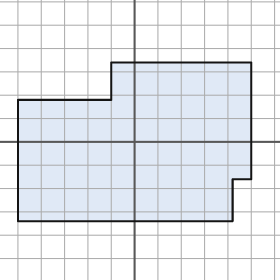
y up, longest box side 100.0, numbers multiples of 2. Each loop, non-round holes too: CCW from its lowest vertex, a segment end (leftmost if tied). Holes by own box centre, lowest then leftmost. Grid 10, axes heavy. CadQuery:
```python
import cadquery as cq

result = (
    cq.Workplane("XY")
    .moveTo(-50.0, -34.0)
    .lineTo(42.0, -34.0)
    .lineTo(42.0, -16.0)
    .lineTo(50.0, -16.0)
    .lineTo(50.0, 34.0)
    .lineTo(-10.0, 34.0)
    .lineTo(-10.0, 18.0)
    .lineTo(-50.0, 18.0)
    .close()
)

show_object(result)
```